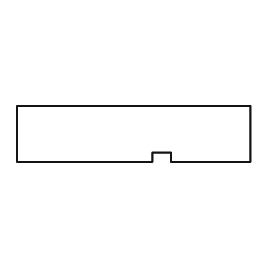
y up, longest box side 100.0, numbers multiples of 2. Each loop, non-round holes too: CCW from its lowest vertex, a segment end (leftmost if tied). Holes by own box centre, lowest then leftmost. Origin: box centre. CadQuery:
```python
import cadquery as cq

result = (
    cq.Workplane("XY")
    .moveTo(-50.0, -12.0)
    .lineTo(8.0, -12.0)
    .lineTo(8.0, -8.0)
    .lineTo(16.0, -8.0)
    .lineTo(16.0, -12.0)
    .lineTo(50.0, -12.0)
    .lineTo(50.0, 12.0)
    .lineTo(-50.0, 12.0)
    .close()
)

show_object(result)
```